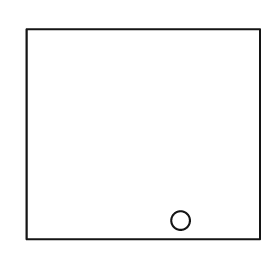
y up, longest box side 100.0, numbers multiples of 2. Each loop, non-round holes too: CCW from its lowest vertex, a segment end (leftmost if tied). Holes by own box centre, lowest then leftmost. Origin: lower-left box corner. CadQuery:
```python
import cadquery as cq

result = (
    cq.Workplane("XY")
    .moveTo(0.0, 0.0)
    .lineTo(100.0, 0.0)
    .lineTo(100.0, 90.0)
    .lineTo(0.0, 90.0)
    .close()
    .moveTo(66.0, 8.0)
    .circle(4.0)
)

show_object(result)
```